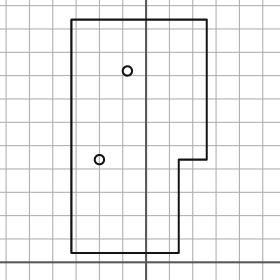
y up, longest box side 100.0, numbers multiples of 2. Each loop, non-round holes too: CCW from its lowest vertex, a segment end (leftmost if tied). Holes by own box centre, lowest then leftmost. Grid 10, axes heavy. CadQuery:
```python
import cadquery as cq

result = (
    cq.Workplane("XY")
    .moveTo(-32.0, 4.0)
    .lineTo(14.0, 4.0)
    .lineTo(14.0, 44.0)
    .lineTo(26.0, 44.0)
    .lineTo(26.0, 104.0)
    .lineTo(-32.0, 104.0)
    .close()
    .moveTo(-20.0, 44.0)
    .circle(2.0)
    .moveTo(-8.0, 82.0)
    .circle(2.0)
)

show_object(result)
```